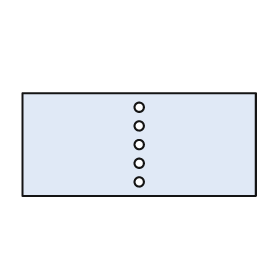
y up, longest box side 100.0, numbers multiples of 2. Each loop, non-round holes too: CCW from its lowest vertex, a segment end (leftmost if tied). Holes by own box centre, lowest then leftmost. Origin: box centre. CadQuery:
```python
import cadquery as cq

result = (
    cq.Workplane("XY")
    .moveTo(-50.0, -22.0)
    .lineTo(50.0, -22.0)
    .lineTo(50.0, 22.0)
    .lineTo(-50.0, 22.0)
    .close()
    .moveTo(0.0, -16.0)
    .circle(2.0)
    .moveTo(0.0, -8.0)
    .circle(2.0)
    .moveTo(0.0, 0.0)
    .circle(2.0)
    .moveTo(0.0, 8.0)
    .circle(2.0)
    .moveTo(0.0, 16.0)
    .circle(2.0)
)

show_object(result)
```